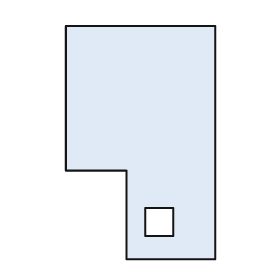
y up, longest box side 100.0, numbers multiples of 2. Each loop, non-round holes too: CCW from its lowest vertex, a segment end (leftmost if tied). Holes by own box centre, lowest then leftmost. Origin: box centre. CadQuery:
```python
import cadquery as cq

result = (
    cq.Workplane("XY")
    .moveTo(-6.0, -50.0)
    .lineTo(32.0, -50.0)
    .lineTo(32.0, 50.0)
    .lineTo(-32.0, 50.0)
    .lineTo(-32.0, -12.0)
    .lineTo(-6.0, -12.0)
    .close()
    .moveTo(2.0, -40.0)
    .lineTo(14.0, -40.0)
    .lineTo(14.0, -28.0)
    .lineTo(2.0, -28.0)
    .close()
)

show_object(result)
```